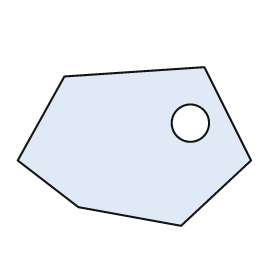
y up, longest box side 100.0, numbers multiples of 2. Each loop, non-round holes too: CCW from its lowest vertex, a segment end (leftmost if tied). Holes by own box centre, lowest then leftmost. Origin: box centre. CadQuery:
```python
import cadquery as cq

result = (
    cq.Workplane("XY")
    .moveTo(20.0, -34.0)
    .lineTo(50.0, -6.0)
    .lineTo(30.0, 34.0)
    .lineTo(-30.0, 30.0)
    .lineTo(-50.0, -6.0)
    .lineTo(-24.0, -26.0)
    .close()
    .moveTo(24.0, 10.0)
    .circle(8.0)
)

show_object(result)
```